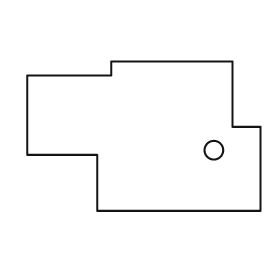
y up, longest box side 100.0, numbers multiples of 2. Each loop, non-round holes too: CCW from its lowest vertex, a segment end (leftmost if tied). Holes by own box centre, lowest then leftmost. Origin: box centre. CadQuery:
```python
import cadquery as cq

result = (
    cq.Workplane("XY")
    .moveTo(-20.0, -32.0)
    .lineTo(50.0, -32.0)
    .lineTo(50.0, 4.0)
    .lineTo(38.0, 4.0)
    .lineTo(38.0, 32.0)
    .lineTo(-14.0, 32.0)
    .lineTo(-14.0, 26.0)
    .lineTo(-50.0, 26.0)
    .lineTo(-50.0, -8.0)
    .lineTo(-20.0, -8.0)
    .close()
    .moveTo(30.0, -6.0)
    .circle(4.0)
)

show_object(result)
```